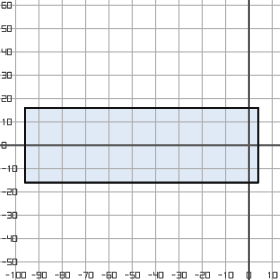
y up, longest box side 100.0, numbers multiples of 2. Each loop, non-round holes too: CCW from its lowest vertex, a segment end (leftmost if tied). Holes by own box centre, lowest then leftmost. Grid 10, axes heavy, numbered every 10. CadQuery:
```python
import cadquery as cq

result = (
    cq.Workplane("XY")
    .moveTo(-96.0, -16.0)
    .lineTo(4.0, -16.0)
    .lineTo(4.0, 16.0)
    .lineTo(-96.0, 16.0)
    .close()
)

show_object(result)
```